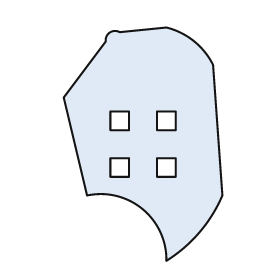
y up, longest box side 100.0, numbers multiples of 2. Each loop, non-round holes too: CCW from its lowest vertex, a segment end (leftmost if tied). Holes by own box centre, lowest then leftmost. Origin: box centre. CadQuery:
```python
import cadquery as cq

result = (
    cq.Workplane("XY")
    .moveTo(10.0, -50.0)
    .threePointArc((24.0, -38.0), (34.0, -22.0))
    .lineTo(30.0, 34.0)
    .threePointArc((22.0, 44.0), (10.0, 50.0))
    .lineTo(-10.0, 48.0)
    .threePointArc((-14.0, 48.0), (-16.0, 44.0))
    .lineTo(-34.0, 20.0)
    .lineTo(-24.0, -22.0)
    .threePointArc((0.0, -28.0), (10.0, -50.0))
    .close()
    .moveTo(-14.0, -14.0)
    .lineTo(-6.0, -14.0)
    .lineTo(-6.0, -6.0)
    .lineTo(-14.0, -6.0)
    .close()
    .moveTo(6.0, -14.0)
    .lineTo(14.0, -14.0)
    .lineTo(14.0, -6.0)
    .lineTo(6.0, -6.0)
    .close()
    .moveTo(-14.0, 6.0)
    .lineTo(-6.0, 6.0)
    .lineTo(-6.0, 14.0)
    .lineTo(-14.0, 14.0)
    .close()
    .moveTo(6.0, 6.0)
    .lineTo(14.0, 6.0)
    .lineTo(14.0, 14.0)
    .lineTo(6.0, 14.0)
    .close()
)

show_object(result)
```